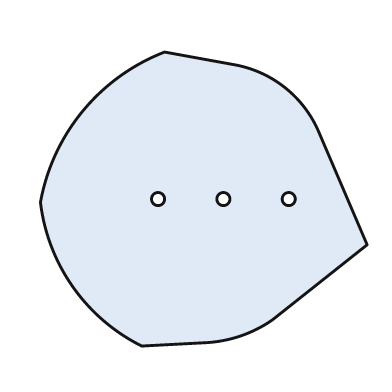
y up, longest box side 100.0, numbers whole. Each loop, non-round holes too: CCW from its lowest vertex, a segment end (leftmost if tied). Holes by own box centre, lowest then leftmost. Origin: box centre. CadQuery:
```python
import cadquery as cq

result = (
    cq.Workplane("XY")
    .moveTo(-19.0, -45.0)
    .lineTo(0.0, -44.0)
    .threePointArc((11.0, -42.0), (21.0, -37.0))
    .lineTo(50.0, -14.0)
    .lineTo(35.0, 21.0)
    .threePointArc((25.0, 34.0), (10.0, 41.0))
    .lineTo(-12.0, 45.0)
    .threePointArc((-37.0, 27.0), (-50.0, -1.0))
    .threePointArc((-40.0, -27.0), (-19.0, -45.0))
    .close()
    .moveTo(-14.0, 0.0)
    .circle(2.0)
    .moveTo(6.0, 0.0)
    .circle(2.0)
    .moveTo(26.0, 0.0)
    .circle(2.0)
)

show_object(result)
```